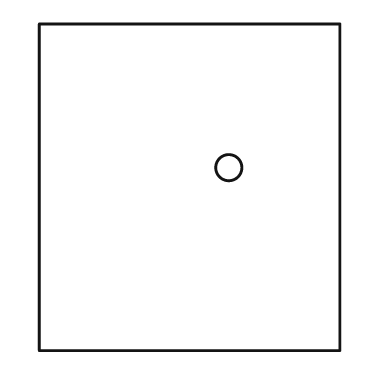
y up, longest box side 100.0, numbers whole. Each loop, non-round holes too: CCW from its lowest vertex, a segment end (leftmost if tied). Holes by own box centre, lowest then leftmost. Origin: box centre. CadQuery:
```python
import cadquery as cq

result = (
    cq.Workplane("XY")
    .moveTo(-46.0, -50.0)
    .lineTo(46.0, -50.0)
    .lineTo(46.0, 50.0)
    .lineTo(-46.0, 50.0)
    .close()
    .moveTo(12.0, 6.0)
    .circle(4.0)
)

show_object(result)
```